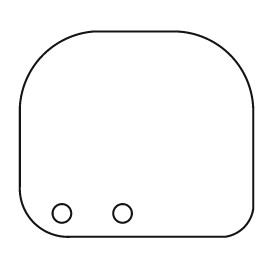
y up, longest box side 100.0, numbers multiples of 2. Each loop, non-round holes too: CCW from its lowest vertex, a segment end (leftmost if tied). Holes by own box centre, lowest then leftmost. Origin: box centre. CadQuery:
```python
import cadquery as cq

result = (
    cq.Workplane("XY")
    .moveTo(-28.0, -44.0)
    .lineTo(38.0, -44.0)
    .threePointArc((46.0, -40.0), (50.0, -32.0))
    .lineTo(50.0, 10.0)
    .threePointArc((40.0, 34.0), (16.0, 44.0))
    .lineTo(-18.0, 44.0)
    .threePointArc((-40.0, 34.0), (-50.0, 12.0))
    .lineTo(-50.0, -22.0)
    .threePointArc((-44.0, -38.0), (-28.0, -44.0))
    .close()
    .moveTo(-32.0, -34.0)
    .circle(4.0)
    .moveTo(-6.0, -34.0)
    .circle(4.0)
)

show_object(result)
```